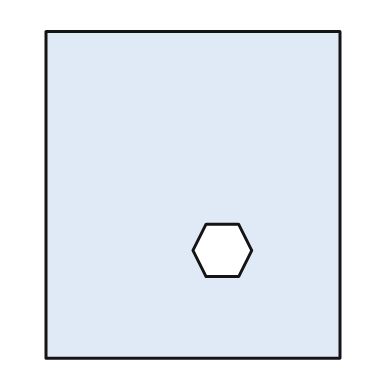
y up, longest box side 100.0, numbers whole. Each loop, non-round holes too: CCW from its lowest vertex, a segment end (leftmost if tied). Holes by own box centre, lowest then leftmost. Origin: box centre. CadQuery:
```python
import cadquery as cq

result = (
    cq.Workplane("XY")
    .moveTo(-45.0, -50.0)
    .lineTo(45.0, -50.0)
    .lineTo(45.0, 50.0)
    .lineTo(-45.0, 50.0)
    .close()
    .moveTo(4.0, -25.0)
    .lineTo(14.0, -25.0)
    .lineTo(18.0, -17.0)
    .lineTo(14.0, -9.0)
    .lineTo(4.0, -9.0)
    .lineTo(0.0, -17.0)
    .close()
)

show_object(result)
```